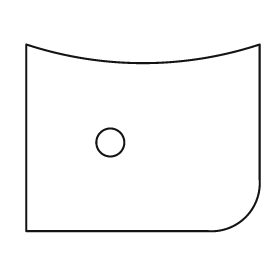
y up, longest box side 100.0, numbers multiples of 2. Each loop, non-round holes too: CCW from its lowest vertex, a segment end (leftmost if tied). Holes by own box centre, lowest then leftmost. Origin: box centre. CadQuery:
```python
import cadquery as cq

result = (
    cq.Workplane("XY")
    .moveTo(-50.0, -40.0)
    .lineTo(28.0, -40.0)
    .threePointArc((44.0, -34.0), (50.0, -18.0))
    .lineTo(50.0, 40.0)
    .threePointArc((0.0, 32.0), (-50.0, 40.0))
    .close()
    .moveTo(-14.0, -2.0)
    .circle(6.0)
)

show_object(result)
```